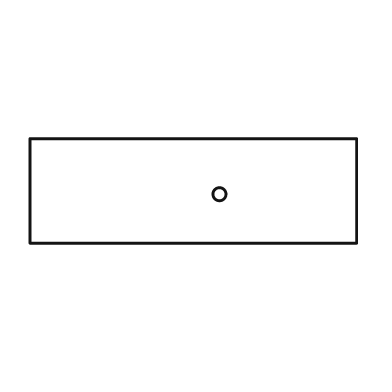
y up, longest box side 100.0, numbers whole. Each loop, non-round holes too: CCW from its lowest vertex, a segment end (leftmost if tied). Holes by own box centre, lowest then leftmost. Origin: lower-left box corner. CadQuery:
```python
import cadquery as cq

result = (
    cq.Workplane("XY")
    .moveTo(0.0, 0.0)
    .lineTo(100.0, 0.0)
    .lineTo(100.0, 32.0)
    .lineTo(0.0, 32.0)
    .close()
    .moveTo(58.0, 15.0)
    .circle(2.0)
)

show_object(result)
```